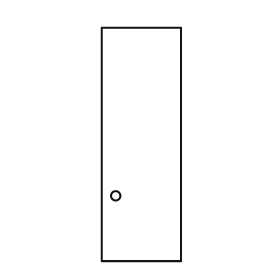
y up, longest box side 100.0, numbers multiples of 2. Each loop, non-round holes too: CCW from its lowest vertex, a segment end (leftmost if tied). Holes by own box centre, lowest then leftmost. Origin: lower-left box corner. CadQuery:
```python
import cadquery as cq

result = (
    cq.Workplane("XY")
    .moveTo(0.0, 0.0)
    .lineTo(34.0, 0.0)
    .lineTo(34.0, 100.0)
    .lineTo(0.0, 100.0)
    .close()
    .moveTo(6.0, 28.0)
    .circle(2.0)
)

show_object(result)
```